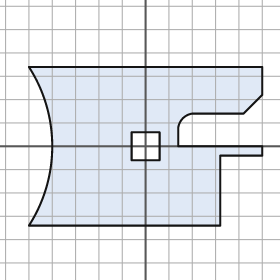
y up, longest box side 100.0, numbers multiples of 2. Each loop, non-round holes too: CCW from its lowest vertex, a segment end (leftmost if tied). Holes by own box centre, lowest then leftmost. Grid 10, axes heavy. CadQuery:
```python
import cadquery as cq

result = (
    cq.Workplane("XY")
    .moveTo(-50.0, -34.0)
    .lineTo(32.0, -34.0)
    .lineTo(32.0, -4.0)
    .lineTo(50.0, -4.0)
    .lineTo(50.0, 0.0)
    .lineTo(14.0, 0.0)
    .lineTo(14.0, 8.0)
    .threePointArc((16.0, 12.0), (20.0, 14.0))
    .lineTo(42.0, 14.0)
    .lineTo(50.0, 22.0)
    .lineTo(50.0, 34.0)
    .lineTo(-50.0, 34.0)
    .threePointArc((-40.0, 0.0), (-50.0, -34.0))
    .close()
    .moveTo(-6.0, -6.0)
    .lineTo(6.0, -6.0)
    .lineTo(6.0, 6.0)
    .lineTo(-6.0, 6.0)
    .close()
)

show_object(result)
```